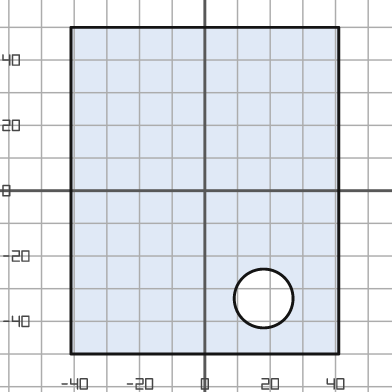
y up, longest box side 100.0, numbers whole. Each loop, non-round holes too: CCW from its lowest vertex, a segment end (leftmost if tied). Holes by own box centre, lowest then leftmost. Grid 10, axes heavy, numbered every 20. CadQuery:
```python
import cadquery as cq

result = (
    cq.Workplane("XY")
    .moveTo(-41.0, -50.0)
    .lineTo(41.0, -50.0)
    .lineTo(41.0, 50.0)
    .lineTo(-41.0, 50.0)
    .close()
    .moveTo(18.0, -33.0)
    .circle(9.0)
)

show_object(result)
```